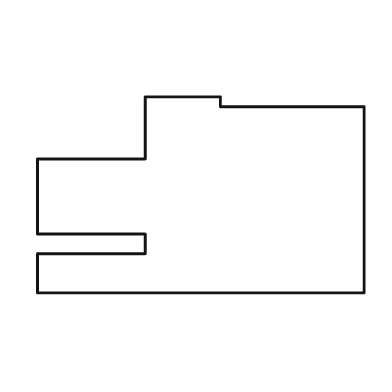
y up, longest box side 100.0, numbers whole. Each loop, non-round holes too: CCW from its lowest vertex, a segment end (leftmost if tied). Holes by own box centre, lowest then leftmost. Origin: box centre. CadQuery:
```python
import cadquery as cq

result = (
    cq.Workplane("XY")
    .moveTo(-50.0, -30.0)
    .lineTo(50.0, -30.0)
    .lineTo(50.0, 27.0)
    .lineTo(6.0, 27.0)
    .lineTo(6.0, 30.0)
    .lineTo(-17.0, 30.0)
    .lineTo(-17.0, 11.0)
    .lineTo(-50.0, 11.0)
    .lineTo(-50.0, -12.0)
    .lineTo(-17.0, -12.0)
    .lineTo(-17.0, -18.0)
    .lineTo(-50.0, -18.0)
    .close()
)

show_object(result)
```